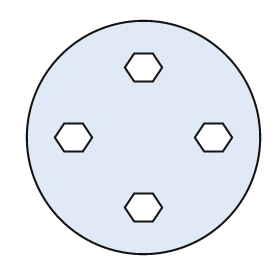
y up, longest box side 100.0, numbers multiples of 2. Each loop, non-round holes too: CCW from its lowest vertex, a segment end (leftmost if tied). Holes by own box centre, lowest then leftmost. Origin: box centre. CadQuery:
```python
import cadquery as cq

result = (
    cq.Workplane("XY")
    .moveTo(0.0, 0.0)
    .circle(50.0)
    .moveTo(-4.0, -36.0)
    .lineTo(4.0, -36.0)
    .lineTo(8.0, -30.0)
    .lineTo(4.0, -24.0)
    .lineTo(-4.0, -24.0)
    .lineTo(-8.0, -30.0)
    .close()
    .moveTo(-34.0, -6.0)
    .lineTo(-26.0, -6.0)
    .lineTo(-22.0, 0.0)
    .lineTo(-26.0, 6.0)
    .lineTo(-34.0, 6.0)
    .lineTo(-38.0, 0.0)
    .close()
    .moveTo(26.0, -6.0)
    .lineTo(34.0, -6.0)
    .lineTo(38.0, 0.0)
    .lineTo(34.0, 6.0)
    .lineTo(26.0, 6.0)
    .lineTo(22.0, 0.0)
    .close()
    .moveTo(-4.0, 24.0)
    .lineTo(4.0, 24.0)
    .lineTo(8.0, 30.0)
    .lineTo(4.0, 36.0)
    .lineTo(-4.0, 36.0)
    .lineTo(-8.0, 30.0)
    .close()
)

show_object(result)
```